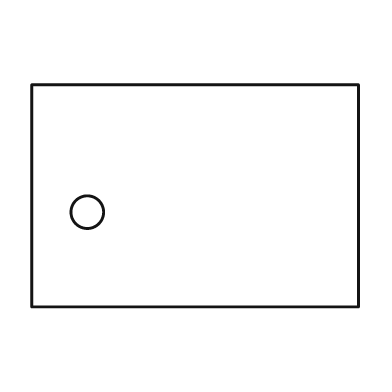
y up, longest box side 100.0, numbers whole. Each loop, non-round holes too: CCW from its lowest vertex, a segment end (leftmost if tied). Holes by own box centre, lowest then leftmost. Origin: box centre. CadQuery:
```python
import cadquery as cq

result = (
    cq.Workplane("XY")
    .moveTo(-50.0, -34.0)
    .lineTo(50.0, -34.0)
    .lineTo(50.0, 34.0)
    .lineTo(-50.0, 34.0)
    .close()
    .moveTo(-33.0, -5.0)
    .circle(5.0)
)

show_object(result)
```